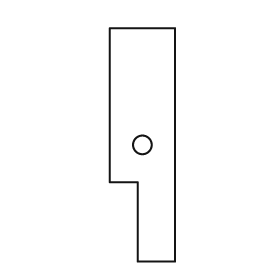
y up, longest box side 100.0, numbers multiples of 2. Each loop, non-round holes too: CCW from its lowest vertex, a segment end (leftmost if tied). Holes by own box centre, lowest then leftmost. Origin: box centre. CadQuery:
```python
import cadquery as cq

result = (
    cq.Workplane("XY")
    .moveTo(-2.0, -50.0)
    .lineTo(14.0, -50.0)
    .lineTo(14.0, 50.0)
    .lineTo(-14.0, 50.0)
    .lineTo(-14.0, -16.0)
    .lineTo(-2.0, -16.0)
    .close()
    .moveTo(0.0, 0.0)
    .circle(4.0)
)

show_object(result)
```